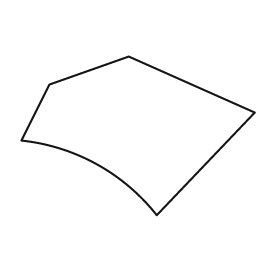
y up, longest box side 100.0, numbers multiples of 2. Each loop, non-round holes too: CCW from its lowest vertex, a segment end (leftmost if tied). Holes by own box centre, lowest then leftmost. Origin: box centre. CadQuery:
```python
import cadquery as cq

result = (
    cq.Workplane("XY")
    .moveTo(8.0, -34.0)
    .lineTo(50.0, 10.0)
    .lineTo(-4.0, 34.0)
    .lineTo(-38.0, 22.0)
    .lineTo(-50.0, -2.0)
    .threePointArc((-18.0, -12.0), (8.0, -34.0))
    .close()
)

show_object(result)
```